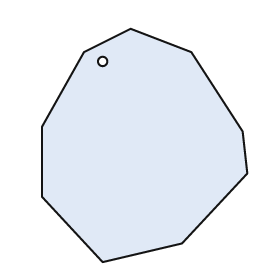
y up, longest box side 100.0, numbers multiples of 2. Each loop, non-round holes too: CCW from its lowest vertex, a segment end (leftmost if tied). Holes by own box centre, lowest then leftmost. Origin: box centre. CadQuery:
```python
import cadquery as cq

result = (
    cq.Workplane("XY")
    .moveTo(-18.0, -50.0)
    .lineTo(16.0, -42.0)
    .lineTo(44.0, -12.0)
    .lineTo(42.0, 6.0)
    .lineTo(20.0, 40.0)
    .lineTo(-6.0, 50.0)
    .lineTo(-26.0, 40.0)
    .lineTo(-44.0, 8.0)
    .lineTo(-44.0, -22.0)
    .close()
    .moveTo(-18.0, 36.0)
    .circle(2.0)
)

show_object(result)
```